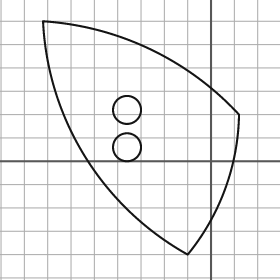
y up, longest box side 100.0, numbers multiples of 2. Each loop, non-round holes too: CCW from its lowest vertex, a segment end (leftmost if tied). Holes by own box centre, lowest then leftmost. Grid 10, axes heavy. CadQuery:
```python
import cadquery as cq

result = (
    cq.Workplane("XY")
    .moveTo(-10.0, -40.0)
    .threePointArc((6.0, -12.0), (12.0, 20.0))
    .threePointArc((-26.0, 48.0), (-72.0, 60.0))
    .threePointArc((-54.0, 2.0), (-10.0, -40.0))
    .close()
    .moveTo(-36.0, 6.0)
    .circle(6.0)
    .moveTo(-36.0, 22.0)
    .circle(6.0)
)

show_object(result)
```